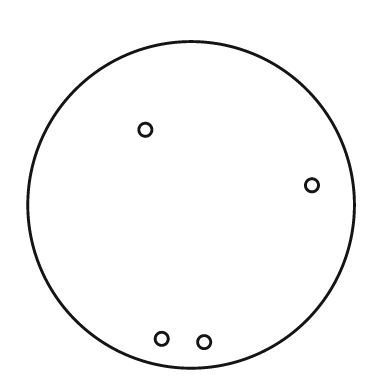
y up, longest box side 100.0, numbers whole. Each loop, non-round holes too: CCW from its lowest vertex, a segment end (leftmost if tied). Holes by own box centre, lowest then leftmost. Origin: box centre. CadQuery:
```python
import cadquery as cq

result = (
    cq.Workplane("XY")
    .moveTo(0.0, 0.0)
    .circle(50.0)
    .moveTo(4.0, -42.0)
    .circle(2.0)
    .moveTo(-9.0, -41.0)
    .circle(2.0)
    .moveTo(37.0, 6.0)
    .circle(2.0)
    .moveTo(-14.0, 23.0)
    .circle(2.0)
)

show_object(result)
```